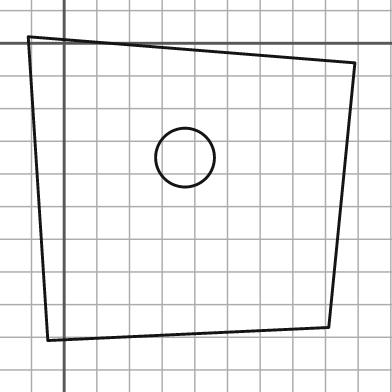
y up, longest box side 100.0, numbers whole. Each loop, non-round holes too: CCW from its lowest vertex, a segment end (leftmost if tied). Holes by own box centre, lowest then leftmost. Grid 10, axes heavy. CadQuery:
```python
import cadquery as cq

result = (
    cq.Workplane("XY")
    .moveTo(-5.0, -91.0)
    .lineTo(81.0, -87.0)
    .lineTo(89.0, -6.0)
    .lineTo(-11.0, 2.0)
    .close()
    .moveTo(37.0, -35.0)
    .circle(9.0)
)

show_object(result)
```